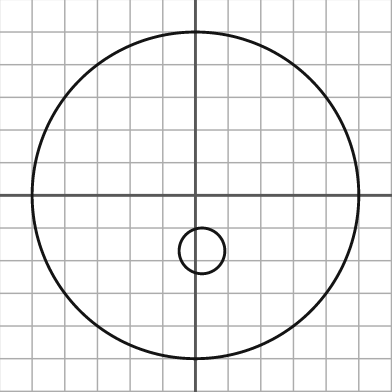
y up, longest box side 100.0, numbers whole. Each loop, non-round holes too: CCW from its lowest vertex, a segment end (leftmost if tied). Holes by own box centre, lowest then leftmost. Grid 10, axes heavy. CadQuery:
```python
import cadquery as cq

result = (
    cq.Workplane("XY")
    .moveTo(0.0, 0.0)
    .circle(50.0)
    .moveTo(2.0, -17.0)
    .circle(7.0)
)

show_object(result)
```